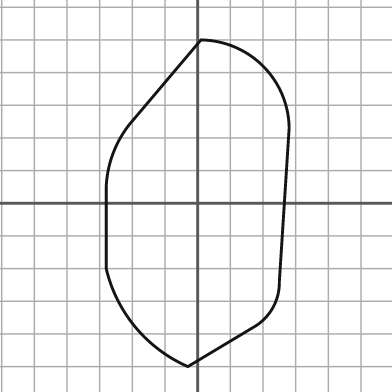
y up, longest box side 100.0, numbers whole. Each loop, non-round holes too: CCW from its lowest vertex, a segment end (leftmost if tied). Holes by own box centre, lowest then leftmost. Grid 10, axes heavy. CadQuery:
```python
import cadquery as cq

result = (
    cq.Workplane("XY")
    .moveTo(-3.0, -50.0)
    .lineTo(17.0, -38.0)
    .threePointArc((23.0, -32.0), (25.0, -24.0))
    .lineTo(28.0, 23.0)
    .threePointArc((20.0, 42.0), (1.0, 50.0))
    .lineTo(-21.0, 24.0)
    .threePointArc((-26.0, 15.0), (-28.0, 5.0))
    .lineTo(-28.0, -20.0)
    .threePointArc((-19.0, -38.0), (-3.0, -50.0))
    .close()
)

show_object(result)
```